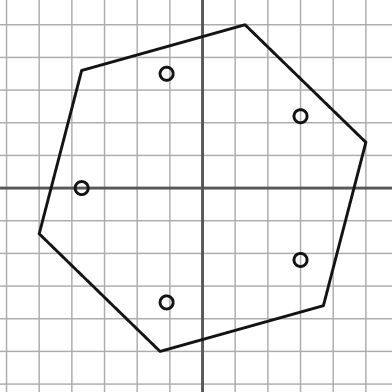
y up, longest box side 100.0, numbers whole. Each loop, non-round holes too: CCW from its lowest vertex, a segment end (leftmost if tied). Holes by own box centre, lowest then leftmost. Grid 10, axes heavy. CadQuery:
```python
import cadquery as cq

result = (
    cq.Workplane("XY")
    .moveTo(-13.0, -50.0)
    .lineTo(37.0, -36.0)
    .lineTo(50.0, 14.0)
    .lineTo(13.0, 50.0)
    .lineTo(-37.0, 36.0)
    .lineTo(-50.0, -14.0)
    .close()
    .moveTo(-11.0, -35.0)
    .circle(2.0)
    .moveTo(30.0, -22.0)
    .circle(2.0)
    .moveTo(-37.0, 0.0)
    .circle(2.0)
    .moveTo(30.0, 22.0)
    .circle(2.0)
    .moveTo(-11.0, 35.0)
    .circle(2.0)
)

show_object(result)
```